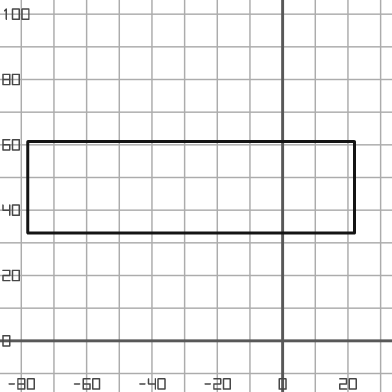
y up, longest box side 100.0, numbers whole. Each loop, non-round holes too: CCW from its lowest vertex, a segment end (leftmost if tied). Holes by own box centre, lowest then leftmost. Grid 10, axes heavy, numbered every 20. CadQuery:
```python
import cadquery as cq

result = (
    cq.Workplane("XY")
    .moveTo(-78.0, 33.0)
    .lineTo(22.0, 33.0)
    .lineTo(22.0, 61.0)
    .lineTo(-78.0, 61.0)
    .close()
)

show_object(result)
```